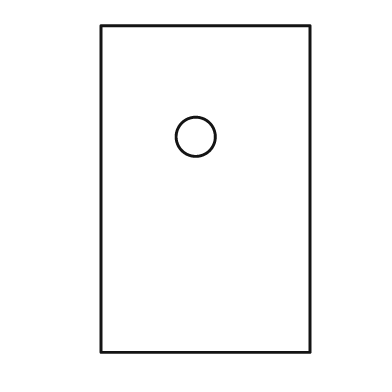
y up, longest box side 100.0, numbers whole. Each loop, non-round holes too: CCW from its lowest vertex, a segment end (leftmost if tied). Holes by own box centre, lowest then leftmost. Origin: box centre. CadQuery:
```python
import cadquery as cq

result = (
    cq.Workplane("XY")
    .moveTo(-32.0, -50.0)
    .lineTo(32.0, -50.0)
    .lineTo(32.0, 50.0)
    .lineTo(-32.0, 50.0)
    .close()
    .moveTo(-3.0, 16.0)
    .circle(6.0)
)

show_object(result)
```